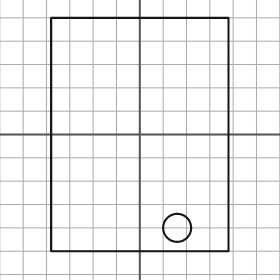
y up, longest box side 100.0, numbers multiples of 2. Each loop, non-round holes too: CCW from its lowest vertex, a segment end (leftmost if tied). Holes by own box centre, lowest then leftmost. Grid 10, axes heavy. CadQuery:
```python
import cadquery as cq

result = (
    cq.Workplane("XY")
    .moveTo(-38.0, -50.0)
    .lineTo(38.0, -50.0)
    .lineTo(38.0, 50.0)
    .lineTo(-38.0, 50.0)
    .close()
    .moveTo(16.0, -40.0)
    .circle(6.0)
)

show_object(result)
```